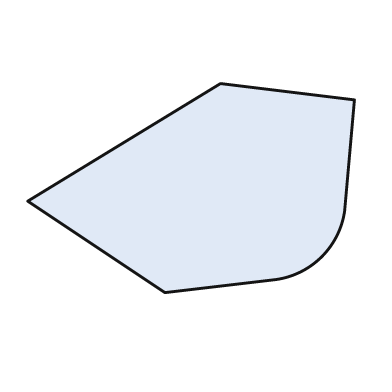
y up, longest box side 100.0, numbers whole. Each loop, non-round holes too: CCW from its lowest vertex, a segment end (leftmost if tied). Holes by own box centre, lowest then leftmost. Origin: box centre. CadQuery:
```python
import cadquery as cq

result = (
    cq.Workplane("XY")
    .moveTo(-8.0, -32.0)
    .lineTo(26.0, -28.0)
    .threePointArc((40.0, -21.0), (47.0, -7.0))
    .lineTo(50.0, 27.0)
    .lineTo(9.0, 32.0)
    .lineTo(-50.0, -4.0)
    .close()
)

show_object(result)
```